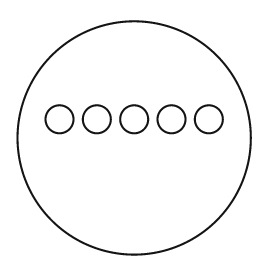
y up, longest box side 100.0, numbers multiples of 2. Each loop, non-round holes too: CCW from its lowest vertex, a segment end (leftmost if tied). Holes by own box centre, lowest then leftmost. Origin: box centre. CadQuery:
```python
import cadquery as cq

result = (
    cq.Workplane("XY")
    .moveTo(0.0, 0.0)
    .circle(50.0)
    .moveTo(-32.0, 8.0)
    .circle(6.0)
    .moveTo(-16.0, 8.0)
    .circle(6.0)
    .moveTo(0.0, 8.0)
    .circle(6.0)
    .moveTo(16.0, 8.0)
    .circle(6.0)
    .moveTo(32.0, 8.0)
    .circle(6.0)
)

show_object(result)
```